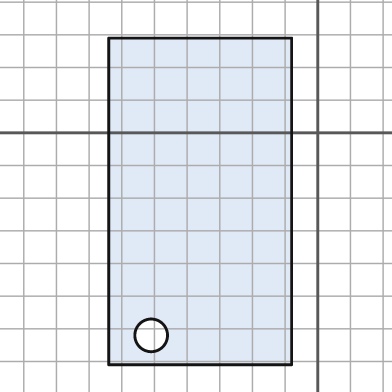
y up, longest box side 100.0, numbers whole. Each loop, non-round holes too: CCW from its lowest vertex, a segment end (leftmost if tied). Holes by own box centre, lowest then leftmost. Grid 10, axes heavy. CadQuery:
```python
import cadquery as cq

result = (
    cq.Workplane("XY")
    .moveTo(-64.0, -71.0)
    .lineTo(-8.0, -71.0)
    .lineTo(-8.0, 29.0)
    .lineTo(-64.0, 29.0)
    .close()
    .moveTo(-51.0, -62.0)
    .circle(5.0)
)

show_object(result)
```